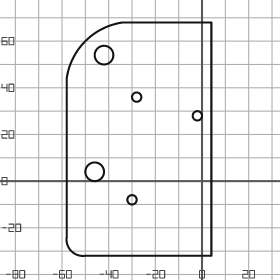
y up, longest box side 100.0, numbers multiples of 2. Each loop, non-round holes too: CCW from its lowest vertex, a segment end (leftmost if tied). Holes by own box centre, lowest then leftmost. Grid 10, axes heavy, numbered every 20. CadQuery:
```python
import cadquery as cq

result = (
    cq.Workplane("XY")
    .moveTo(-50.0, -32.0)
    .lineTo(4.0, -32.0)
    .lineTo(4.0, 68.0)
    .lineTo(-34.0, 68.0)
    .threePointArc((-50.0, 60.0), (-58.0, 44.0))
    .lineTo(-58.0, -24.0)
    .threePointArc((-56.0, -30.0), (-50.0, -32.0))
    .close()
    .moveTo(-30.0, -8.0)
    .circle(2.0)
    .moveTo(-46.0, 4.0)
    .circle(4.0)
    .moveTo(-2.0, 28.0)
    .circle(2.0)
    .moveTo(-28.0, 36.0)
    .circle(2.0)
    .moveTo(-42.0, 54.0)
    .circle(4.0)
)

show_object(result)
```